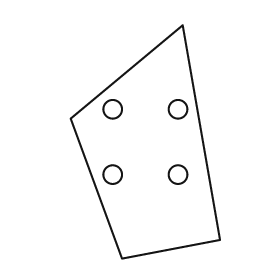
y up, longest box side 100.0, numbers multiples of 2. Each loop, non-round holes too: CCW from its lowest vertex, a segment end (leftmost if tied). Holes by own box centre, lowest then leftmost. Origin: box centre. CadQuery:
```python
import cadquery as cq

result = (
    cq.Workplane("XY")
    .moveTo(-10.0, -50.0)
    .lineTo(32.0, -42.0)
    .lineTo(16.0, 50.0)
    .lineTo(-32.0, 10.0)
    .close()
    .moveTo(-14.0, -14.0)
    .circle(4.0)
    .moveTo(14.0, -14.0)
    .circle(4.0)
    .moveTo(-14.0, 14.0)
    .circle(4.0)
    .moveTo(14.0, 14.0)
    .circle(4.0)
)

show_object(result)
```